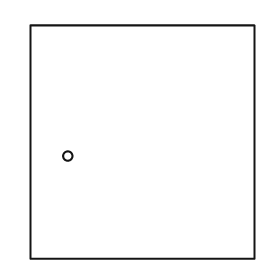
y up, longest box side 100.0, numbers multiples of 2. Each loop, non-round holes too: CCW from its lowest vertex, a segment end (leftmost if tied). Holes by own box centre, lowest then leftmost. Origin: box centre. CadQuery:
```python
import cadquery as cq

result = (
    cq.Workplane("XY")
    .moveTo(-48.0, -50.0)
    .lineTo(48.0, -50.0)
    .lineTo(48.0, 50.0)
    .lineTo(-48.0, 50.0)
    .close()
    .moveTo(-32.0, -6.0)
    .circle(2.0)
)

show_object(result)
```